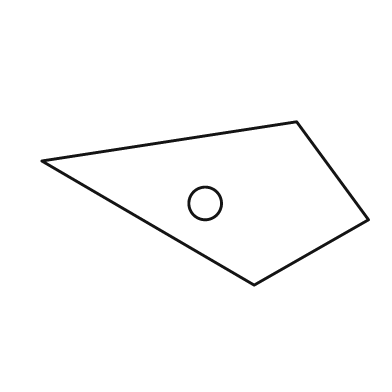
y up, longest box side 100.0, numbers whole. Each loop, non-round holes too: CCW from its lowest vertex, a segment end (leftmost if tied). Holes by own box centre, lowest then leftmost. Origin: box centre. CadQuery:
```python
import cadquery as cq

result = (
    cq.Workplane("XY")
    .moveTo(15.0, -25.0)
    .lineTo(50.0, -5.0)
    .lineTo(28.0, 25.0)
    .lineTo(-50.0, 13.0)
    .close()
    .moveTo(0.0, 0.0)
    .circle(5.0)
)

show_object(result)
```